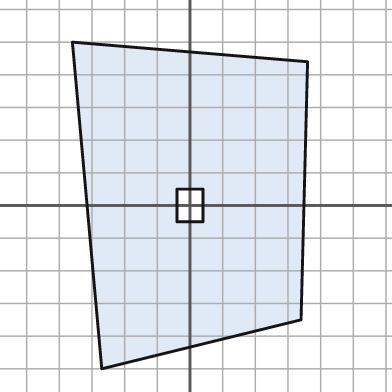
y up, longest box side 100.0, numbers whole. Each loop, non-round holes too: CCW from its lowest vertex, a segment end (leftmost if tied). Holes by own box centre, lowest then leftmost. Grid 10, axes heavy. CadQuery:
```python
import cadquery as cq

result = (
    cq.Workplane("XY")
    .moveTo(-27.0, -50.0)
    .lineTo(34.0, -35.0)
    .lineTo(36.0, 44.0)
    .lineTo(-36.0, 50.0)
    .close()
    .moveTo(-4.0, -5.0)
    .lineTo(4.0, -5.0)
    .lineTo(4.0, 5.0)
    .lineTo(-4.0, 5.0)
    .close()
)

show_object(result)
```